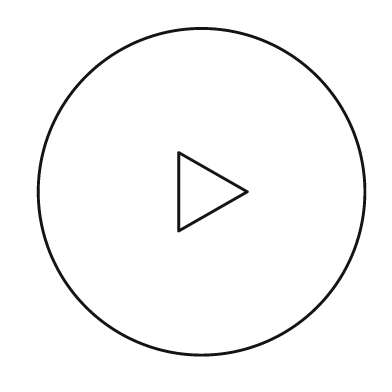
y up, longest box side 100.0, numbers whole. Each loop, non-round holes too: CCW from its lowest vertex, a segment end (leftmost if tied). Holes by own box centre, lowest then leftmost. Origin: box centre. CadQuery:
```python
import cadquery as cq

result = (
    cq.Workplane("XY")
    .moveTo(0.0, 0.0)
    .circle(50.0)
    .moveTo(-7.0, -12.0)
    .lineTo(14.0, 0.0)
    .lineTo(-7.0, 12.0)
    .close()
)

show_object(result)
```